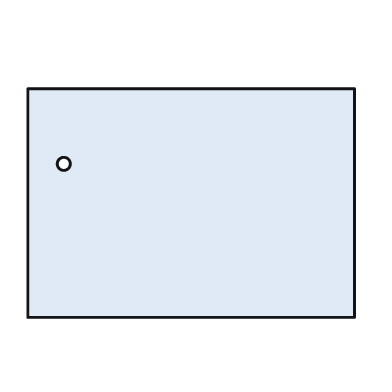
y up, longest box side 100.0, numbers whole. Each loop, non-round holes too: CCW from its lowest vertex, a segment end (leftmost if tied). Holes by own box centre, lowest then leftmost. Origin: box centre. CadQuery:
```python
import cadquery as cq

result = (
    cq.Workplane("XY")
    .moveTo(-50.0, -35.0)
    .lineTo(50.0, -35.0)
    .lineTo(50.0, 35.0)
    .lineTo(-50.0, 35.0)
    .close()
    .moveTo(-39.0, 12.0)
    .circle(2.0)
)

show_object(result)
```